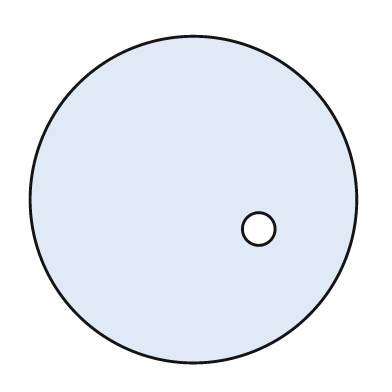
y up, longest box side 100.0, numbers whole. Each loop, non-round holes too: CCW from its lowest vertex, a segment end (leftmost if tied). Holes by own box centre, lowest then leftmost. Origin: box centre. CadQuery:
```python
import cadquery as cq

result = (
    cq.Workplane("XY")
    .moveTo(0.0, 0.0)
    .circle(50.0)
    .moveTo(20.0, -9.0)
    .circle(5.0)
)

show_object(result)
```